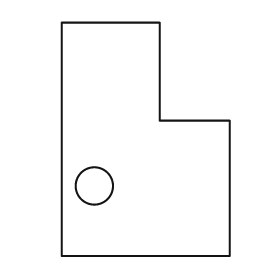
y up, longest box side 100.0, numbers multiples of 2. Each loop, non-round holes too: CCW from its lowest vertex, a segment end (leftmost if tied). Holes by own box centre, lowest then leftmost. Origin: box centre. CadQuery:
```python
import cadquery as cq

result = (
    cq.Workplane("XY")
    .moveTo(-36.0, -50.0)
    .lineTo(36.0, -50.0)
    .lineTo(36.0, 8.0)
    .lineTo(6.0, 8.0)
    .lineTo(6.0, 50.0)
    .lineTo(-36.0, 50.0)
    .close()
    .moveTo(-22.0, -20.0)
    .circle(8.0)
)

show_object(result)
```